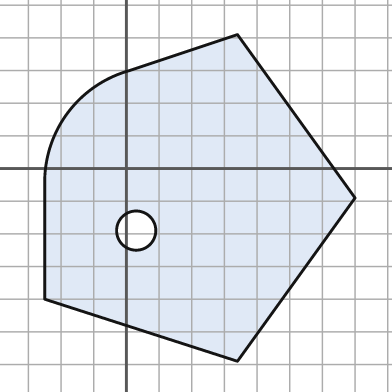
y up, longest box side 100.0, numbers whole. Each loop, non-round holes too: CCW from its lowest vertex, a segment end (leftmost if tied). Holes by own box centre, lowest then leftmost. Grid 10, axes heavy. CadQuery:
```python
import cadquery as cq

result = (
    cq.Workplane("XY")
    .moveTo(34.0, -59.0)
    .lineTo(70.0, -9.0)
    .lineTo(34.0, 41.0)
    .lineTo(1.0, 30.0)
    .threePointArc((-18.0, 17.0), (-25.0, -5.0))
    .lineTo(-25.0, -40.0)
    .close()
    .moveTo(3.0, -19.0)
    .circle(6.0)
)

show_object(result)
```